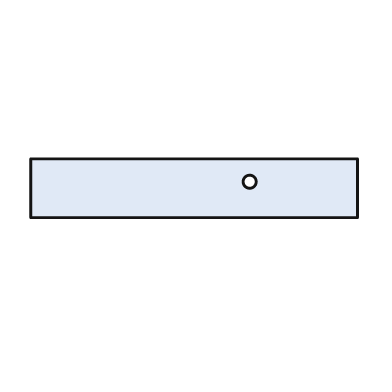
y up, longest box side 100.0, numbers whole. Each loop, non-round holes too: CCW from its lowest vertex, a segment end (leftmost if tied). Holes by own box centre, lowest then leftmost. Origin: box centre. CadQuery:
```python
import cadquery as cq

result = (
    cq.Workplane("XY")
    .moveTo(-50.0, -9.0)
    .lineTo(50.0, -9.0)
    .lineTo(50.0, 9.0)
    .lineTo(-50.0, 9.0)
    .close()
    .moveTo(17.0, 2.0)
    .circle(2.0)
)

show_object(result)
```